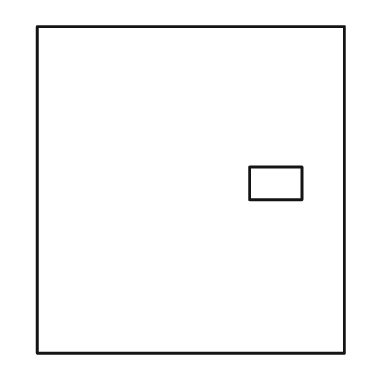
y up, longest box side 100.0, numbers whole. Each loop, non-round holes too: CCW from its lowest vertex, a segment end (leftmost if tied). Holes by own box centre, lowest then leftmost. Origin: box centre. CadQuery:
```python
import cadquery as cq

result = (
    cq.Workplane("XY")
    .moveTo(-47.0, -50.0)
    .lineTo(47.0, -50.0)
    .lineTo(47.0, 50.0)
    .lineTo(-47.0, 50.0)
    .close()
    .moveTo(18.0, -3.0)
    .lineTo(34.0, -3.0)
    .lineTo(34.0, 7.0)
    .lineTo(18.0, 7.0)
    .close()
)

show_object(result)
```